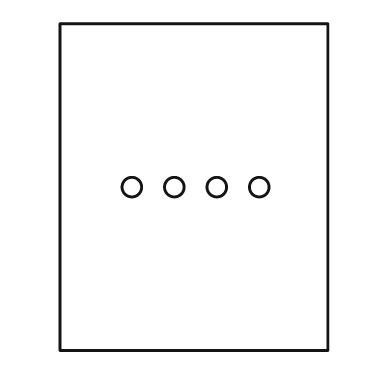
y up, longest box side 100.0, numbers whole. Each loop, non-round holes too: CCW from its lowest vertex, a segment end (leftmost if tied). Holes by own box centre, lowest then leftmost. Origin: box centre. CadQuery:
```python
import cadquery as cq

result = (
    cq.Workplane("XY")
    .moveTo(-41.0, -50.0)
    .lineTo(41.0, -50.0)
    .lineTo(41.0, 50.0)
    .lineTo(-41.0, 50.0)
    .close()
    .moveTo(-19.0, 0.0)
    .circle(3.0)
    .moveTo(-6.0, 0.0)
    .circle(3.0)
    .moveTo(7.0, 0.0)
    .circle(3.0)
    .moveTo(20.0, 0.0)
    .circle(3.0)
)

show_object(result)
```